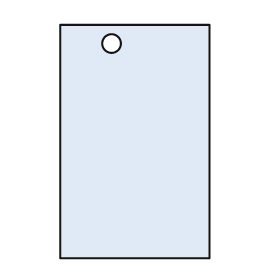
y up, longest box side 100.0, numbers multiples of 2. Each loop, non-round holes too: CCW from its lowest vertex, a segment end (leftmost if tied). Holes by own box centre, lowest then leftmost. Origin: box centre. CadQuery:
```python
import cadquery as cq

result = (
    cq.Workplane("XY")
    .moveTo(-32.0, -50.0)
    .lineTo(32.0, -50.0)
    .lineTo(32.0, 50.0)
    .lineTo(-32.0, 50.0)
    .close()
    .moveTo(-10.0, 42.0)
    .circle(4.0)
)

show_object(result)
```